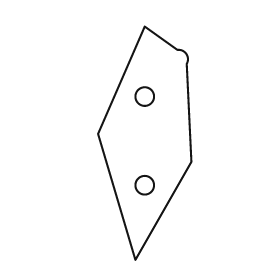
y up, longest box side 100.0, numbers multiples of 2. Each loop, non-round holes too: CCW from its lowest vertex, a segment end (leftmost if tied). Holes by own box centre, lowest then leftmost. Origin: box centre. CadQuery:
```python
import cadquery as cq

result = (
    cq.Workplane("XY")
    .moveTo(-4.0, -50.0)
    .lineTo(20.0, -8.0)
    .lineTo(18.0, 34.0)
    .threePointArc((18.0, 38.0), (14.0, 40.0))
    .lineTo(0.0, 50.0)
    .lineTo(-20.0, 4.0)
    .close()
    .moveTo(0.0, -18.0)
    .circle(4.0)
    .moveTo(0.0, 20.0)
    .circle(4.0)
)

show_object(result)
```